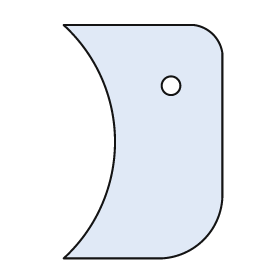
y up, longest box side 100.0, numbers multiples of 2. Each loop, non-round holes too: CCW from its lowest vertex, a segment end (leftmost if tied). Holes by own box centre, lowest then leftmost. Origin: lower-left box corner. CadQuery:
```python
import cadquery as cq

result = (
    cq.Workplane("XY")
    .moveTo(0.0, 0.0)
    .lineTo(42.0, 0.0)
    .threePointArc((60.0, 8.0), (68.0, 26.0))
    .lineTo(68.0, 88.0)
    .threePointArc((64.0, 96.0), (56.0, 100.0))
    .lineTo(0.0, 100.0)
    .threePointArc((22.0, 50.0), (0.0, 0.0))
    .close()
    .moveTo(46.0, 74.0)
    .circle(4.0)
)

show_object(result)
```